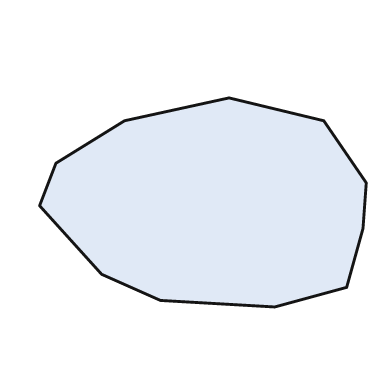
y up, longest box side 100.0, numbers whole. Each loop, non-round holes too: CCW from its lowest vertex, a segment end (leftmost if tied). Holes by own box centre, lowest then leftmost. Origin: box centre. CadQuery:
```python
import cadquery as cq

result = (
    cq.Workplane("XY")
    .moveTo(22.0, -32.0)
    .lineTo(44.0, -26.0)
    .lineTo(49.0, -8.0)
    .lineTo(50.0, 6.0)
    .lineTo(37.0, 25.0)
    .lineTo(8.0, 32.0)
    .lineTo(-24.0, 25.0)
    .lineTo(-45.0, 12.0)
    .lineTo(-50.0, -1.0)
    .lineTo(-31.0, -22.0)
    .lineTo(-13.0, -30.0)
    .close()
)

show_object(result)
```